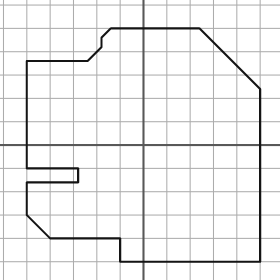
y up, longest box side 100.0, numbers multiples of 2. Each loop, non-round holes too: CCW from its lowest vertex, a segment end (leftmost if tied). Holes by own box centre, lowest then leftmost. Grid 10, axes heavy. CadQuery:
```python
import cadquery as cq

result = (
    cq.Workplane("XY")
    .moveTo(-10.0, -50.0)
    .lineTo(50.0, -50.0)
    .lineTo(50.0, 24.0)
    .lineTo(24.0, 50.0)
    .lineTo(-14.0, 50.0)
    .lineTo(-18.0, 46.0)
    .lineTo(-18.0, 42.0)
    .lineTo(-24.0, 36.0)
    .lineTo(-50.0, 36.0)
    .lineTo(-50.0, -10.0)
    .lineTo(-28.0, -10.0)
    .lineTo(-28.0, -16.0)
    .lineTo(-50.0, -16.0)
    .lineTo(-50.0, -30.0)
    .lineTo(-40.0, -40.0)
    .lineTo(-10.0, -40.0)
    .close()
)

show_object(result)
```